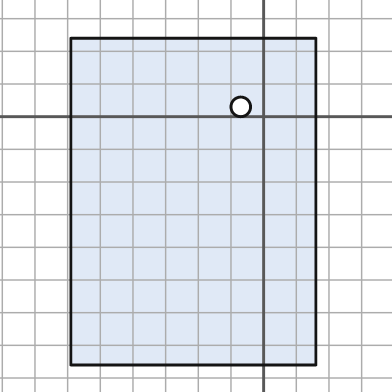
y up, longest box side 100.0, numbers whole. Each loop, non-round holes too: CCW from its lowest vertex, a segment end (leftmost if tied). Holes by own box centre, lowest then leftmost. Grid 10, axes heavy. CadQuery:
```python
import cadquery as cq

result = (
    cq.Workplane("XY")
    .moveTo(-59.0, -76.0)
    .lineTo(16.0, -76.0)
    .lineTo(16.0, 24.0)
    .lineTo(-59.0, 24.0)
    .close()
    .moveTo(-7.0, 3.0)
    .circle(3.0)
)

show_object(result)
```